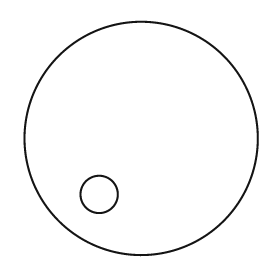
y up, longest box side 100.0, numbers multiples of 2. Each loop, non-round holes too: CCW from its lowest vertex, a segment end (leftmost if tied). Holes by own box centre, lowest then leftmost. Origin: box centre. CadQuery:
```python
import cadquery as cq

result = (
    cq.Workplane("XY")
    .moveTo(0.0, 0.0)
    .circle(50.0)
    .moveTo(-18.0, -24.0)
    .circle(8.0)
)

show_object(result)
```